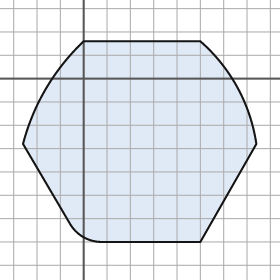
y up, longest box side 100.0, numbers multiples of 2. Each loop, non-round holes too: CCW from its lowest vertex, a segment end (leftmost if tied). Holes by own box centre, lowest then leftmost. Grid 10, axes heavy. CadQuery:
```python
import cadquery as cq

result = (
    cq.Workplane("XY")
    .moveTo(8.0, -70.0)
    .lineTo(50.0, -70.0)
    .lineTo(74.0, -28.0)
    .threePointArc((66.0, -4.0), (50.0, 16.0))
    .lineTo(0.0, 16.0)
    .threePointArc((-16.0, -4.0), (-26.0, -28.0))
    .lineTo(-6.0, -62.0)
    .threePointArc((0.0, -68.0), (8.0, -70.0))
    .close()
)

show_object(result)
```